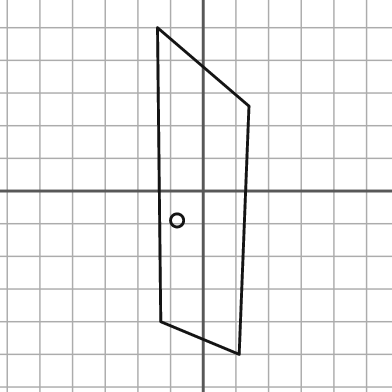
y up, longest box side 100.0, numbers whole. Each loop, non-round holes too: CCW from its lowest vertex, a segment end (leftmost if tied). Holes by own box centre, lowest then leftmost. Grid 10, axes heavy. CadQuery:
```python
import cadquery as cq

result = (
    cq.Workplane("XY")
    .moveTo(11.0, -50.0)
    .lineTo(14.0, 26.0)
    .lineTo(-14.0, 50.0)
    .lineTo(-13.0, -40.0)
    .close()
    .moveTo(-8.0, -9.0)
    .circle(2.0)
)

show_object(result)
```